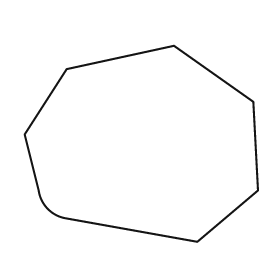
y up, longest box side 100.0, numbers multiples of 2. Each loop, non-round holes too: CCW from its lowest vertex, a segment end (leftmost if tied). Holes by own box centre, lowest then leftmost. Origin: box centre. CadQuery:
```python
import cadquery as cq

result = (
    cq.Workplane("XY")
    .moveTo(24.0, -42.0)
    .lineTo(50.0, -20.0)
    .lineTo(48.0, 18.0)
    .lineTo(14.0, 42.0)
    .lineTo(-32.0, 32.0)
    .lineTo(-50.0, 4.0)
    .lineTo(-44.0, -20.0)
    .threePointArc((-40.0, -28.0), (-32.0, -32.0))
    .close()
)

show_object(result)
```